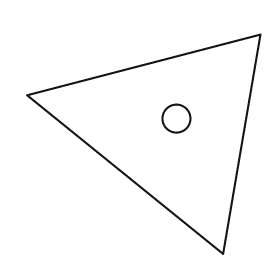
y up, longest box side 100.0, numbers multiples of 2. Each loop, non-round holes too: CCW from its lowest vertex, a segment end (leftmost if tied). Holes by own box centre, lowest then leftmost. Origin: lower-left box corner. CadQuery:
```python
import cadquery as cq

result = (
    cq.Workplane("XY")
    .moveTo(84.0, 0.0)
    .lineTo(100.0, 94.0)
    .lineTo(0.0, 68.0)
    .close()
    .moveTo(64.0, 58.0)
    .circle(6.0)
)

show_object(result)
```